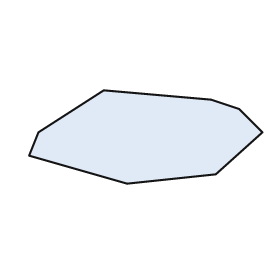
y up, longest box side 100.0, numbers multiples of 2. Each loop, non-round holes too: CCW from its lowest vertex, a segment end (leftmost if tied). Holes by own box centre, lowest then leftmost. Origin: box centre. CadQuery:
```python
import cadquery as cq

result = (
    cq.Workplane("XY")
    .moveTo(-8.0, -20.0)
    .lineTo(30.0, -16.0)
    .lineTo(50.0, 2.0)
    .lineTo(40.0, 12.0)
    .lineTo(28.0, 16.0)
    .lineTo(-18.0, 20.0)
    .lineTo(-46.0, 2.0)
    .lineTo(-50.0, -8.0)
    .close()
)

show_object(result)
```